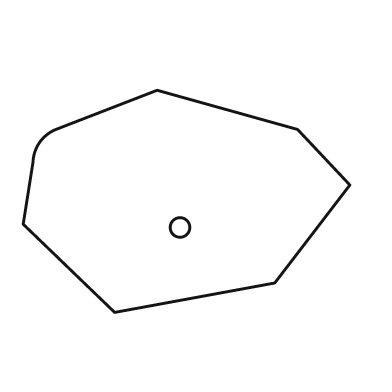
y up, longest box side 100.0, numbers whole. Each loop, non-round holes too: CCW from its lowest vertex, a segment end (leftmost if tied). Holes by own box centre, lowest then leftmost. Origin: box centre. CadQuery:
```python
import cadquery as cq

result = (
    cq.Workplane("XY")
    .moveTo(-22.0, -34.0)
    .lineTo(27.0, -25.0)
    .lineTo(50.0, 5.0)
    .lineTo(34.0, 22.0)
    .lineTo(-9.0, 34.0)
    .lineTo(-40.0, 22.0)
    .threePointArc((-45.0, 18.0), (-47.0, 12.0))
    .lineTo(-50.0, -7.0)
    .close()
    .moveTo(-2.0, -8.0)
    .circle(3.0)
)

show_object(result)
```